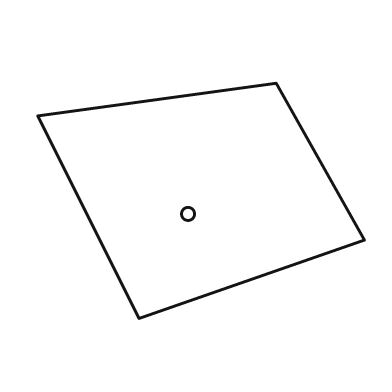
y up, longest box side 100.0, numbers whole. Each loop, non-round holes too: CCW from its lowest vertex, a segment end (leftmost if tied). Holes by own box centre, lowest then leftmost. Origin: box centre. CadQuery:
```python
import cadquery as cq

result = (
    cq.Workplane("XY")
    .moveTo(-19.0, -36.0)
    .lineTo(50.0, -12.0)
    .lineTo(23.0, 36.0)
    .lineTo(-50.0, 26.0)
    .close()
    .moveTo(-4.0, -4.0)
    .circle(2.0)
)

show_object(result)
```